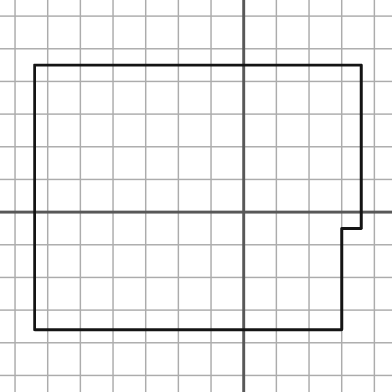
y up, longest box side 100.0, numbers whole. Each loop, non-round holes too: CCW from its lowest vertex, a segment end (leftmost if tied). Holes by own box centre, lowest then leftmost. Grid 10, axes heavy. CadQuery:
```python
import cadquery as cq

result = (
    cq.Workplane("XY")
    .moveTo(-64.0, -36.0)
    .lineTo(30.0, -36.0)
    .lineTo(30.0, -5.0)
    .lineTo(36.0, -5.0)
    .lineTo(36.0, 45.0)
    .lineTo(-64.0, 45.0)
    .close()
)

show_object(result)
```